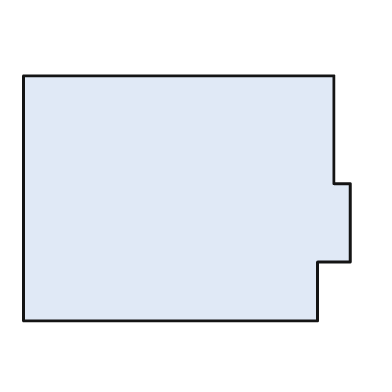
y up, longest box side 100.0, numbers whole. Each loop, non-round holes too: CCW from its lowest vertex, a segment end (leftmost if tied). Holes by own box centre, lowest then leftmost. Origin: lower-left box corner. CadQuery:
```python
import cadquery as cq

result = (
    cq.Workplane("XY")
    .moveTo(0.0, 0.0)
    .lineTo(90.0, 0.0)
    .lineTo(90.0, 18.0)
    .lineTo(100.0, 18.0)
    .lineTo(100.0, 42.0)
    .lineTo(95.0, 42.0)
    .lineTo(95.0, 75.0)
    .lineTo(0.0, 75.0)
    .close()
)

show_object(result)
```